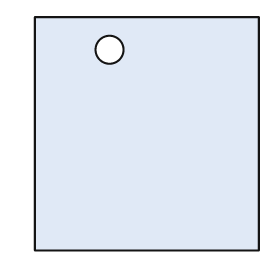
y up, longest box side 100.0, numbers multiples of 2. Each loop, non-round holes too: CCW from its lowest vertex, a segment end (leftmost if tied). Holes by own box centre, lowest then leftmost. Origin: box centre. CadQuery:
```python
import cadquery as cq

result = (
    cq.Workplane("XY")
    .moveTo(-48.0, -50.0)
    .lineTo(48.0, -50.0)
    .lineTo(48.0, 50.0)
    .lineTo(-48.0, 50.0)
    .close()
    .moveTo(-16.0, 36.0)
    .circle(6.0)
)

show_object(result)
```